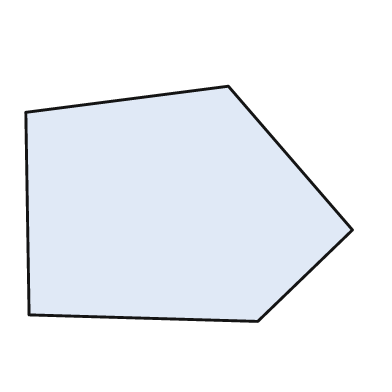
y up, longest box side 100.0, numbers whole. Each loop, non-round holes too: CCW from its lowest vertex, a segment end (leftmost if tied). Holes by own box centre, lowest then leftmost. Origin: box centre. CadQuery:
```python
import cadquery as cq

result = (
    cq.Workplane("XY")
    .moveTo(21.0, -36.0)
    .lineTo(50.0, -8.0)
    .lineTo(12.0, 36.0)
    .lineTo(-50.0, 28.0)
    .lineTo(-49.0, -34.0)
    .close()
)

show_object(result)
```